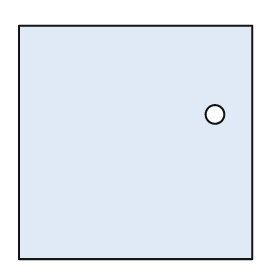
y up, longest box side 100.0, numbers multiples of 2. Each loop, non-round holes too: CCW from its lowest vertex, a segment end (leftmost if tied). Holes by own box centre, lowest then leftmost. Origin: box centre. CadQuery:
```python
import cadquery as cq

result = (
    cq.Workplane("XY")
    .moveTo(-50.0, -50.0)
    .lineTo(50.0, -50.0)
    .lineTo(50.0, 50.0)
    .lineTo(-50.0, 50.0)
    .close()
    .moveTo(34.0, 12.0)
    .circle(4.0)
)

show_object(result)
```